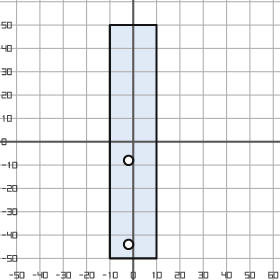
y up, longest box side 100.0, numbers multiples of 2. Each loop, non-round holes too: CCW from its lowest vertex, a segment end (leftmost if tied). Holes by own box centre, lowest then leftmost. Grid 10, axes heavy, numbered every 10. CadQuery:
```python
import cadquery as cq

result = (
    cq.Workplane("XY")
    .moveTo(-10.0, -50.0)
    .lineTo(10.0, -50.0)
    .lineTo(10.0, 50.0)
    .lineTo(-10.0, 50.0)
    .close()
    .moveTo(-2.0, -44.0)
    .circle(2.0)
    .moveTo(-2.0, -8.0)
    .circle(2.0)
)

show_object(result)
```